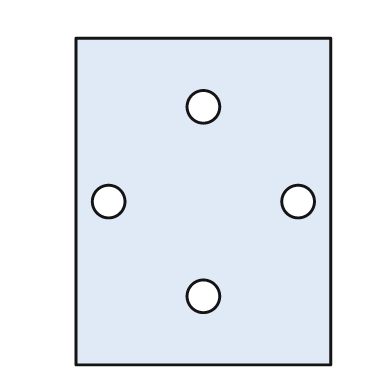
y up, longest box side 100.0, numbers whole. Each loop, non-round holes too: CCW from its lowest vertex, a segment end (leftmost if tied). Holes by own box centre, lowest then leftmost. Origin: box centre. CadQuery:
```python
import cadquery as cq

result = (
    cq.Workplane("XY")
    .moveTo(-39.0, -50.0)
    .lineTo(39.0, -50.0)
    .lineTo(39.0, 50.0)
    .lineTo(-39.0, 50.0)
    .close()
    .moveTo(0.0, -29.0)
    .circle(5.0)
    .moveTo(-29.0, 0.0)
    .circle(5.0)
    .moveTo(29.0, 0.0)
    .circle(5.0)
    .moveTo(0.0, 29.0)
    .circle(5.0)
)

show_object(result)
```